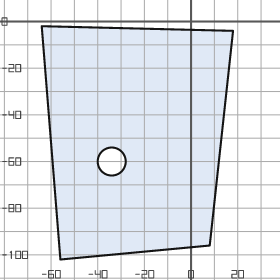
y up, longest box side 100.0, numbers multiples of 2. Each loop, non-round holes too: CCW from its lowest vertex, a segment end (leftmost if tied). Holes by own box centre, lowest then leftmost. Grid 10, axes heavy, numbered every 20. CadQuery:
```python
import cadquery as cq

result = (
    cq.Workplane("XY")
    .moveTo(-56.0, -102.0)
    .lineTo(8.0, -96.0)
    .lineTo(18.0, -4.0)
    .lineTo(-64.0, -2.0)
    .close()
    .moveTo(-34.0, -60.0)
    .circle(6.0)
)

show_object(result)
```